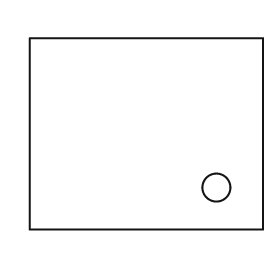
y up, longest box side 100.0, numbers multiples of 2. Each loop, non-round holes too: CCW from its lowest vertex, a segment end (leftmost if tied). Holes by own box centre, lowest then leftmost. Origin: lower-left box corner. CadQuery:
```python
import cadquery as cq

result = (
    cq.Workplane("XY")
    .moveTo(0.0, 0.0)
    .lineTo(100.0, 0.0)
    .lineTo(100.0, 82.0)
    .lineTo(0.0, 82.0)
    .close()
    .moveTo(80.0, 18.0)
    .circle(6.0)
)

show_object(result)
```